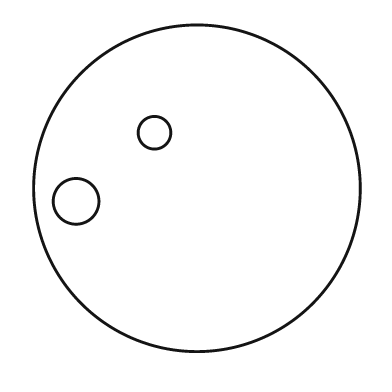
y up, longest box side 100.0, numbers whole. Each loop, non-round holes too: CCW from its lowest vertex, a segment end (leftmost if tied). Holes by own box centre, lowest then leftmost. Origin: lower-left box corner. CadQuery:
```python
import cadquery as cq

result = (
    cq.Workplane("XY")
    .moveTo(50.0, 50.0)
    .circle(50.0)
    .moveTo(13.0, 46.0)
    .circle(7.0)
    .moveTo(37.0, 67.0)
    .circle(5.0)
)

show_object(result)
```